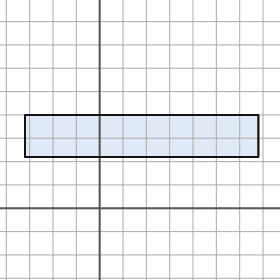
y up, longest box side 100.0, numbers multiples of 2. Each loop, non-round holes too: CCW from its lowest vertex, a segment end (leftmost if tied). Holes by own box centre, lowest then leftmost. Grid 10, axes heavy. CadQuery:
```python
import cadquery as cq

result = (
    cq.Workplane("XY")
    .moveTo(-32.0, 22.0)
    .lineTo(68.0, 22.0)
    .lineTo(68.0, 40.0)
    .lineTo(-32.0, 40.0)
    .close()
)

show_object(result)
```